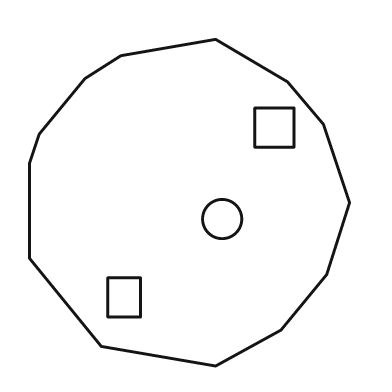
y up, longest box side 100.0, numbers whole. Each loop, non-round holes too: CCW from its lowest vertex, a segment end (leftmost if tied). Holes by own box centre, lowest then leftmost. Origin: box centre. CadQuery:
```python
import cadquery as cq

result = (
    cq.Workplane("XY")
    .moveTo(8.0, -50.0)
    .lineTo(28.0, -39.0)
    .lineTo(42.0, -22.0)
    .lineTo(49.0, 0.0)
    .lineTo(41.0, 24.0)
    .lineTo(30.0, 37.0)
    .lineTo(8.0, 50.0)
    .lineTo(-21.0, 45.0)
    .lineTo(-32.0, 38.0)
    .lineTo(-46.0, 21.0)
    .lineTo(-49.0, 12.0)
    .lineTo(-49.0, -17.0)
    .lineTo(-27.0, -44.0)
    .close()
    .moveTo(-25.0, -35.0)
    .lineTo(-15.0, -35.0)
    .lineTo(-15.0, -23.0)
    .lineTo(-25.0, -23.0)
    .close()
    .moveTo(10.0, -5.0)
    .circle(6.0)
    .moveTo(20.0, 17.0)
    .lineTo(32.0, 17.0)
    .lineTo(32.0, 29.0)
    .lineTo(20.0, 29.0)
    .close()
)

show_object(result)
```